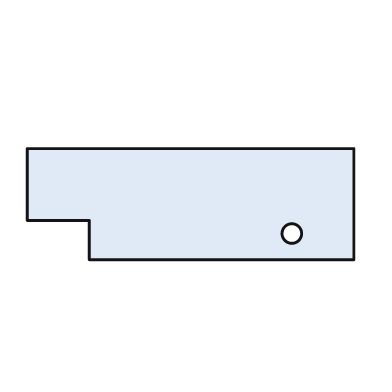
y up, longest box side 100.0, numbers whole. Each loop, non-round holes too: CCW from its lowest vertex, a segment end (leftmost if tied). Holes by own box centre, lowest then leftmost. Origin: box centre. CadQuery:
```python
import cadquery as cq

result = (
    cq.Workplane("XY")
    .moveTo(-31.0, -17.0)
    .lineTo(50.0, -17.0)
    .lineTo(50.0, 17.0)
    .lineTo(-50.0, 17.0)
    .lineTo(-50.0, -5.0)
    .lineTo(-31.0, -5.0)
    .close()
    .moveTo(31.0, -9.0)
    .circle(3.0)
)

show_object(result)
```